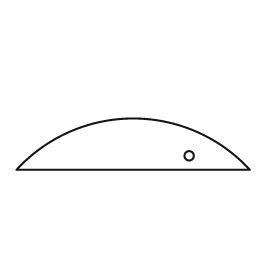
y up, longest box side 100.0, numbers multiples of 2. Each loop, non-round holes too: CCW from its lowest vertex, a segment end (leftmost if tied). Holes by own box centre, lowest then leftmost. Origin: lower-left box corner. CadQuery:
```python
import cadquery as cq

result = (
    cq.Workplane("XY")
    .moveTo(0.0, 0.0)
    .lineTo(100.0, 0.0)
    .threePointArc((50.0, 22.0), (0.0, 0.0))
    .close()
    .moveTo(74.0, 6.0)
    .circle(2.0)
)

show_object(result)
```